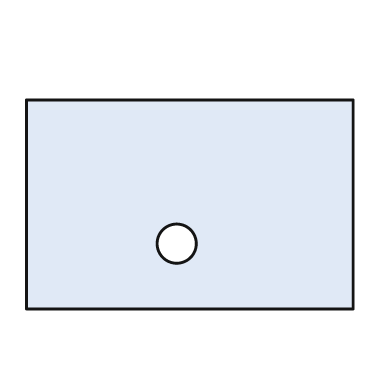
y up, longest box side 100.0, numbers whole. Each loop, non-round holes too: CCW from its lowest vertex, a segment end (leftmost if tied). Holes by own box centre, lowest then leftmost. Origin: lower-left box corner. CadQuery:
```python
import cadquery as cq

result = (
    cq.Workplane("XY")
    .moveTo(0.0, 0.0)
    .lineTo(100.0, 0.0)
    .lineTo(100.0, 64.0)
    .lineTo(0.0, 64.0)
    .close()
    .moveTo(46.0, 20.0)
    .circle(6.0)
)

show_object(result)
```